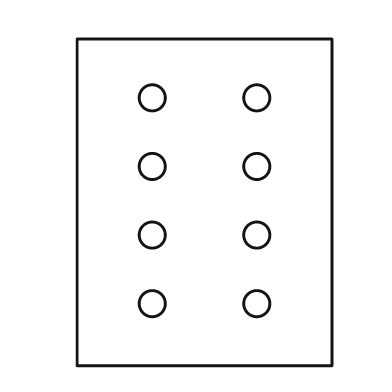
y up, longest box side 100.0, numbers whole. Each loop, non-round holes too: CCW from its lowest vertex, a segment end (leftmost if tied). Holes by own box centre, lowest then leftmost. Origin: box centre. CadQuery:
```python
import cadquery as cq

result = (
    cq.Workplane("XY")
    .moveTo(-39.0, -50.0)
    .lineTo(39.0, -50.0)
    .lineTo(39.0, 50.0)
    .lineTo(-39.0, 50.0)
    .close()
    .moveTo(-16.0, -31.0)
    .circle(4.0)
    .moveTo(16.0, -31.0)
    .circle(4.0)
    .moveTo(-16.0, -10.0)
    .circle(4.0)
    .moveTo(16.0, -10.0)
    .circle(4.0)
    .moveTo(-16.0, 11.0)
    .circle(4.0)
    .moveTo(16.0, 11.0)
    .circle(4.0)
    .moveTo(-16.0, 32.0)
    .circle(4.0)
    .moveTo(16.0, 32.0)
    .circle(4.0)
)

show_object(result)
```